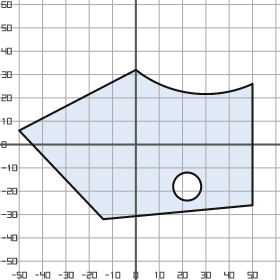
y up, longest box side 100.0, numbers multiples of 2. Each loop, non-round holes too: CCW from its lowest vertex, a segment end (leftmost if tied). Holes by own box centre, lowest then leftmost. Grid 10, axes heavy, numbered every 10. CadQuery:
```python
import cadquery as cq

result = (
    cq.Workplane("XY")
    .moveTo(-14.0, -32.0)
    .lineTo(50.0, -26.0)
    .lineTo(50.0, 26.0)
    .threePointArc((24.0, 22.0), (0.0, 32.0))
    .lineTo(-50.0, 6.0)
    .close()
    .moveTo(22.0, -18.0)
    .circle(6.0)
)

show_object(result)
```